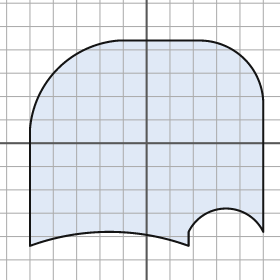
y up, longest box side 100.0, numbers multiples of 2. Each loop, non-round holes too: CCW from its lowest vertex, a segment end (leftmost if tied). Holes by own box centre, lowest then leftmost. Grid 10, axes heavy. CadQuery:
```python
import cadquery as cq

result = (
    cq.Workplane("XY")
    .moveTo(-50.0, -44.0)
    .threePointArc((-16.0, -38.0), (18.0, -44.0))
    .lineTo(18.0, -38.0)
    .threePointArc((34.0, -28.0), (50.0, -38.0))
    .lineTo(50.0, 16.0)
    .threePointArc((42.0, 36.0), (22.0, 44.0))
    .lineTo(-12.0, 44.0)
    .threePointArc((-38.0, 32.0), (-50.0, 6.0))
    .close()
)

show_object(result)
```